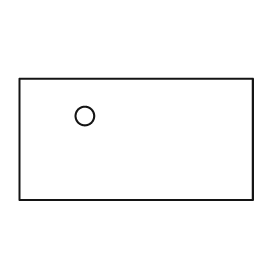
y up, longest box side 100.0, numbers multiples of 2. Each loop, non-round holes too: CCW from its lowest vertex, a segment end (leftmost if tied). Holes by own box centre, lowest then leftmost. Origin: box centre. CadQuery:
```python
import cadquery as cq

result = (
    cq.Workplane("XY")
    .moveTo(-50.0, -26.0)
    .lineTo(50.0, -26.0)
    .lineTo(50.0, 26.0)
    .lineTo(-50.0, 26.0)
    .close()
    .moveTo(-22.0, 10.0)
    .circle(4.0)
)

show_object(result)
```